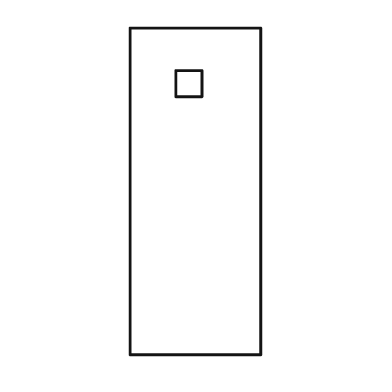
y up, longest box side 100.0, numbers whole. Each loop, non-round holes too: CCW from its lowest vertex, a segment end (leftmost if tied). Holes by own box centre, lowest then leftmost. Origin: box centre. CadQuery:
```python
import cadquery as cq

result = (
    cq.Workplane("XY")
    .moveTo(-20.0, -50.0)
    .lineTo(20.0, -50.0)
    .lineTo(20.0, 50.0)
    .lineTo(-20.0, 50.0)
    .close()
    .moveTo(-6.0, 29.0)
    .lineTo(2.0, 29.0)
    .lineTo(2.0, 37.0)
    .lineTo(-6.0, 37.0)
    .close()
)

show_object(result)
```